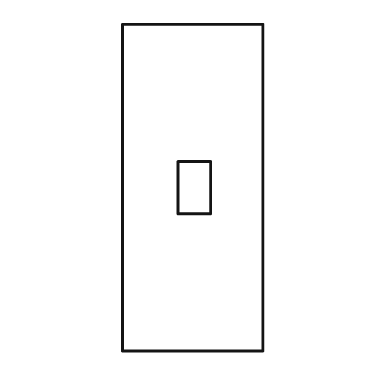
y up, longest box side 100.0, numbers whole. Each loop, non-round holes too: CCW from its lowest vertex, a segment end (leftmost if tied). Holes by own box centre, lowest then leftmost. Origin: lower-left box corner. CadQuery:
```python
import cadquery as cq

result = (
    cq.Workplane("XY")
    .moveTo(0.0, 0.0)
    .lineTo(43.0, 0.0)
    .lineTo(43.0, 100.0)
    .lineTo(0.0, 100.0)
    .close()
    .moveTo(17.0, 42.0)
    .lineTo(27.0, 42.0)
    .lineTo(27.0, 58.0)
    .lineTo(17.0, 58.0)
    .close()
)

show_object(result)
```